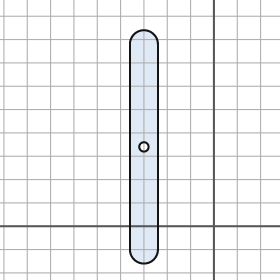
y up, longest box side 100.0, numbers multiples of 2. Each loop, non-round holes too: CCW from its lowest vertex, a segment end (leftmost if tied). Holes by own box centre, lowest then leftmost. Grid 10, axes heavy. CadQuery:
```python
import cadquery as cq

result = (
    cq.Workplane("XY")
    .moveTo(-36.0, -10.0)
    .threePointArc((-30.0, -16.0), (-24.0, -10.0))
    .lineTo(-24.0, 78.0)
    .threePointArc((-30.0, 84.0), (-36.0, 78.0))
    .close()
    .moveTo(-30.0, 34.0)
    .circle(2.0)
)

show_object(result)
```